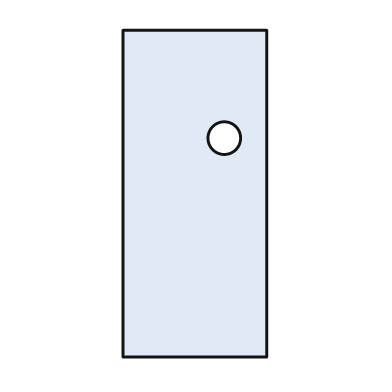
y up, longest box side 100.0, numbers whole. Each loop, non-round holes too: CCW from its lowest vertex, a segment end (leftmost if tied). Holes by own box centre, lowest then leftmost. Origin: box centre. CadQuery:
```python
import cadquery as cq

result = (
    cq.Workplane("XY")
    .moveTo(-22.0, -50.0)
    .lineTo(22.0, -50.0)
    .lineTo(22.0, 50.0)
    .lineTo(-22.0, 50.0)
    .close()
    .moveTo(9.0, 17.0)
    .circle(5.0)
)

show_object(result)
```